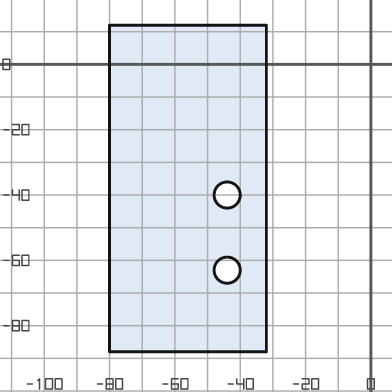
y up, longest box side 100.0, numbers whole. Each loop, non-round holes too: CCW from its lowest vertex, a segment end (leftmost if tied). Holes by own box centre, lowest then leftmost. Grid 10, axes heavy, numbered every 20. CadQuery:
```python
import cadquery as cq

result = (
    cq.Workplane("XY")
    .moveTo(-80.0, -88.0)
    .lineTo(-32.0, -88.0)
    .lineTo(-32.0, 12.0)
    .lineTo(-80.0, 12.0)
    .close()
    .moveTo(-44.0, -63.0)
    .circle(4.0)
    .moveTo(-44.0, -40.0)
    .circle(4.0)
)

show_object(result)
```